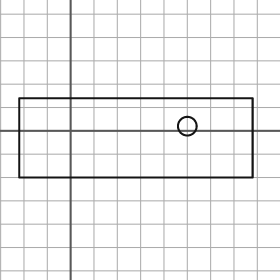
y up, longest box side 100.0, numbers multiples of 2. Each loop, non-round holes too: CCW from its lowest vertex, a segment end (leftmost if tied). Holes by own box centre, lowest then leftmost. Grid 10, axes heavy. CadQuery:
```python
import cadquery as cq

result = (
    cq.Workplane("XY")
    .moveTo(-22.0, -20.0)
    .lineTo(78.0, -20.0)
    .lineTo(78.0, 14.0)
    .lineTo(-22.0, 14.0)
    .close()
    .moveTo(50.0, 2.0)
    .circle(4.0)
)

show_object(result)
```